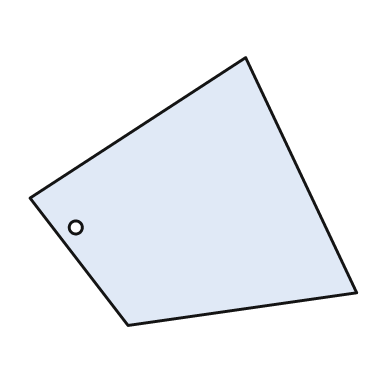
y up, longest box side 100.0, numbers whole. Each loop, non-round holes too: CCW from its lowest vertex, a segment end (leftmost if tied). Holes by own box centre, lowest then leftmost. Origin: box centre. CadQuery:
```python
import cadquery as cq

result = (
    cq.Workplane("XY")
    .moveTo(-20.0, -41.0)
    .lineTo(50.0, -31.0)
    .lineTo(16.0, 41.0)
    .lineTo(-50.0, -2.0)
    .close()
    .moveTo(-36.0, -11.0)
    .circle(2.0)
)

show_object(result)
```